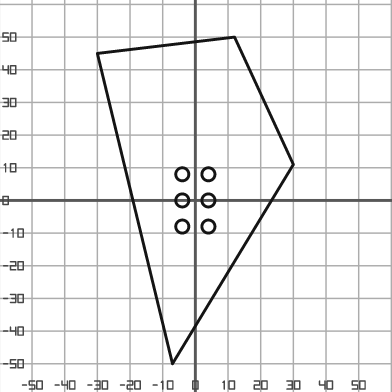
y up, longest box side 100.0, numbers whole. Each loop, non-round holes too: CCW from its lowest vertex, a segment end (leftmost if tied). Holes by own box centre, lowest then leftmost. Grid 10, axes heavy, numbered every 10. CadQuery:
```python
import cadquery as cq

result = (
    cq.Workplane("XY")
    .moveTo(-7.0, -50.0)
    .lineTo(30.0, 11.0)
    .lineTo(12.0, 50.0)
    .lineTo(-30.0, 45.0)
    .close()
    .moveTo(-4.0, -8.0)
    .circle(2.0)
    .moveTo(4.0, -8.0)
    .circle(2.0)
    .moveTo(-4.0, 0.0)
    .circle(2.0)
    .moveTo(4.0, 0.0)
    .circle(2.0)
    .moveTo(-4.0, 8.0)
    .circle(2.0)
    .moveTo(4.0, 8.0)
    .circle(2.0)
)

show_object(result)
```